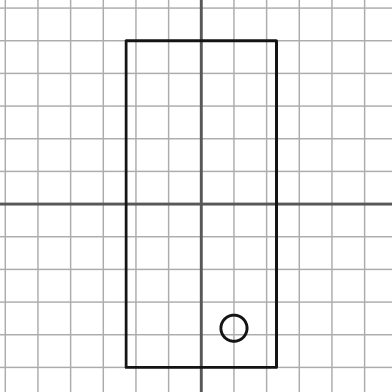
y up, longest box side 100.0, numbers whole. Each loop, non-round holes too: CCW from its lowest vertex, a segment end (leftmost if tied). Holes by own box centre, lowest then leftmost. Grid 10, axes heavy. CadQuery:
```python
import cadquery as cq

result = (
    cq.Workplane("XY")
    .moveTo(-23.0, -50.0)
    .lineTo(23.0, -50.0)
    .lineTo(23.0, 50.0)
    .lineTo(-23.0, 50.0)
    .close()
    .moveTo(10.0, -38.0)
    .circle(4.0)
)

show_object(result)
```